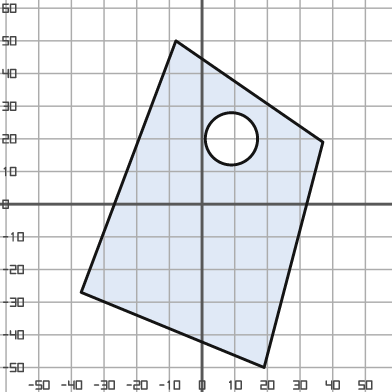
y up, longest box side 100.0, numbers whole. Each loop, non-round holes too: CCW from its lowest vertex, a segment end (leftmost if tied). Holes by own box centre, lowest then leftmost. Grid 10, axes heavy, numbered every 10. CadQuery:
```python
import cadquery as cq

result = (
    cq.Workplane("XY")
    .moveTo(19.0, -50.0)
    .lineTo(37.0, 19.0)
    .lineTo(-8.0, 50.0)
    .lineTo(-37.0, -27.0)
    .close()
    .moveTo(9.0, 20.0)
    .circle(8.0)
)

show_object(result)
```